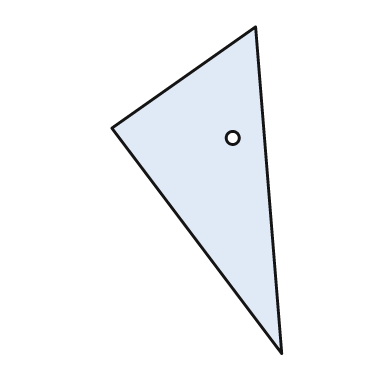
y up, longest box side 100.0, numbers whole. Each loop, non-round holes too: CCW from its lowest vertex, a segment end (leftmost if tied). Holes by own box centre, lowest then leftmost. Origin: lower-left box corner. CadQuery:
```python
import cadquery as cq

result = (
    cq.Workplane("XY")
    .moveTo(52.0, 0.0)
    .lineTo(44.0, 100.0)
    .lineTo(0.0, 69.0)
    .close()
    .moveTo(37.0, 66.0)
    .circle(2.0)
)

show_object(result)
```